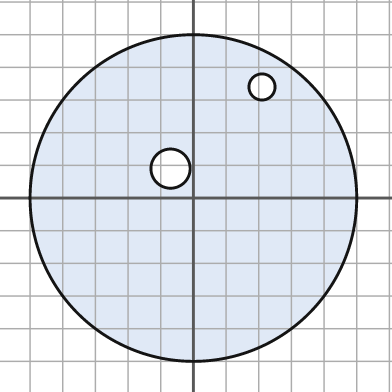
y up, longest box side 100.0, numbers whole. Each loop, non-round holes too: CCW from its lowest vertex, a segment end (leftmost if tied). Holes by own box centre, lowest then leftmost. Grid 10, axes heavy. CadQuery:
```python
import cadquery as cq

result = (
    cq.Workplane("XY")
    .moveTo(0.0, 0.0)
    .circle(50.0)
    .moveTo(-7.0, 9.0)
    .circle(6.0)
    .moveTo(21.0, 34.0)
    .circle(4.0)
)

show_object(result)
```